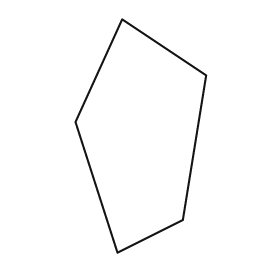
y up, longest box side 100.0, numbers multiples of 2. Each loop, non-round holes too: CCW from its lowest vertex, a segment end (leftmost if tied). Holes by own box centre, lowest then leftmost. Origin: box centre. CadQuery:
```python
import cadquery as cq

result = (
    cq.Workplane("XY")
    .moveTo(-10.0, -50.0)
    .lineTo(18.0, -36.0)
    .lineTo(28.0, 26.0)
    .lineTo(-8.0, 50.0)
    .lineTo(-28.0, 6.0)
    .close()
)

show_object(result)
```